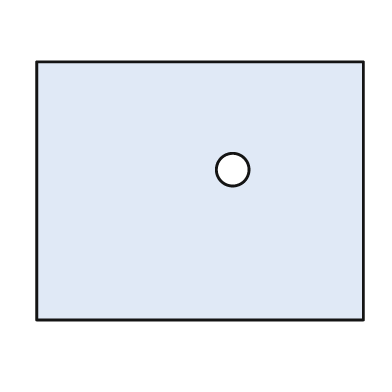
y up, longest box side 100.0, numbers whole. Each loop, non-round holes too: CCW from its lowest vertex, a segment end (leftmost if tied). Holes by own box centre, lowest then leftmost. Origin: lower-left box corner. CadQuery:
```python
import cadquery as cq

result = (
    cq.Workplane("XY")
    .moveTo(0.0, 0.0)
    .lineTo(100.0, 0.0)
    .lineTo(100.0, 79.0)
    .lineTo(0.0, 79.0)
    .close()
    .moveTo(60.0, 46.0)
    .circle(5.0)
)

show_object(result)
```